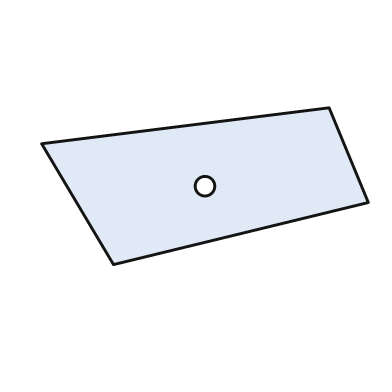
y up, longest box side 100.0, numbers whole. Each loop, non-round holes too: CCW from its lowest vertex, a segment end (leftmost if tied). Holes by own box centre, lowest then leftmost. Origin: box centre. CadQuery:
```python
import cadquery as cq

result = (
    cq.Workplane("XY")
    .moveTo(-28.0, -24.0)
    .lineTo(50.0, -5.0)
    .lineTo(38.0, 24.0)
    .lineTo(-50.0, 13.0)
    .close()
    .moveTo(0.0, 0.0)
    .circle(3.0)
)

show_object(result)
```